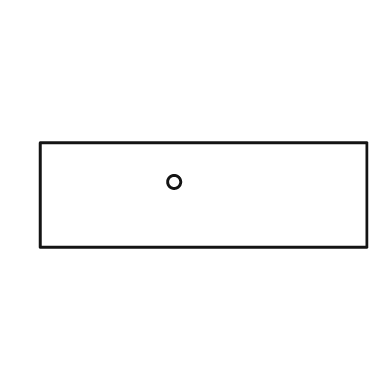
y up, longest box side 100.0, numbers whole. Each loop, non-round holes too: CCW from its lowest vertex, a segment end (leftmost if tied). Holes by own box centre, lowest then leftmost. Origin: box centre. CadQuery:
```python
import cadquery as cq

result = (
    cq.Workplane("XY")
    .moveTo(-50.0, -16.0)
    .lineTo(50.0, -16.0)
    .lineTo(50.0, 16.0)
    .lineTo(-50.0, 16.0)
    .close()
    .moveTo(-9.0, 4.0)
    .circle(2.0)
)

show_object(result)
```